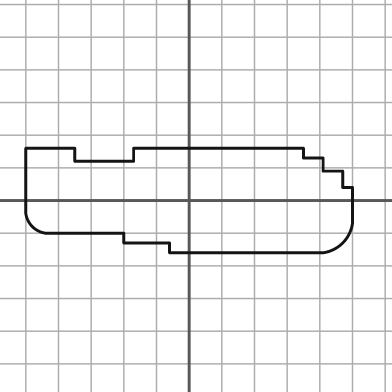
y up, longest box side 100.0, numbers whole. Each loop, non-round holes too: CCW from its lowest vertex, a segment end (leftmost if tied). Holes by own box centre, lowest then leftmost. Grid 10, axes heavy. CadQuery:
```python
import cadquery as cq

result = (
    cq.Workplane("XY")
    .moveTo(-6.0, -16.0)
    .lineTo(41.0, -16.0)
    .threePointArc((47.0, -13.0), (50.0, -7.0))
    .lineTo(50.0, 4.0)
    .lineTo(47.0, 4.0)
    .lineTo(47.0, 9.0)
    .lineTo(41.0, 9.0)
    .lineTo(41.0, 13.0)
    .lineTo(35.0, 13.0)
    .lineTo(35.0, 16.0)
    .lineTo(-17.0, 16.0)
    .lineTo(-17.0, 12.0)
    .lineTo(-35.0, 12.0)
    .lineTo(-35.0, 16.0)
    .lineTo(-50.0, 16.0)
    .lineTo(-50.0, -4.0)
    .threePointArc((-48.0, -8.0), (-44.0, -10.0))
    .lineTo(-20.0, -10.0)
    .lineTo(-20.0, -13.0)
    .lineTo(-6.0, -13.0)
    .close()
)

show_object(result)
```